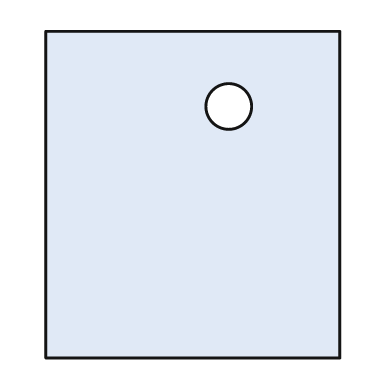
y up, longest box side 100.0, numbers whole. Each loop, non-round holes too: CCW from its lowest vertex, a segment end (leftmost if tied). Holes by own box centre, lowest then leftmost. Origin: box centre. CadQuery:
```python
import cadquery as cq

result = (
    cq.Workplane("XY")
    .moveTo(-45.0, -50.0)
    .lineTo(45.0, -50.0)
    .lineTo(45.0, 50.0)
    .lineTo(-45.0, 50.0)
    .close()
    .moveTo(11.0, 27.0)
    .circle(7.0)
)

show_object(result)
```